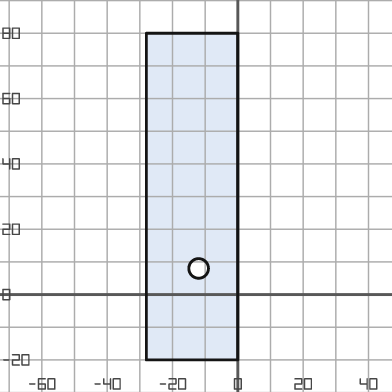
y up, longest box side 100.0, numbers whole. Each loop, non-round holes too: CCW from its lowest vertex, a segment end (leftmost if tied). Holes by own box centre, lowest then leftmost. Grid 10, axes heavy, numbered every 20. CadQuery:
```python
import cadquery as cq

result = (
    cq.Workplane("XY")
    .moveTo(-28.0, -20.0)
    .lineTo(0.0, -20.0)
    .lineTo(0.0, 80.0)
    .lineTo(-28.0, 80.0)
    .close()
    .moveTo(-12.0, 8.0)
    .circle(3.0)
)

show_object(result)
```